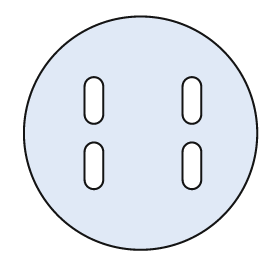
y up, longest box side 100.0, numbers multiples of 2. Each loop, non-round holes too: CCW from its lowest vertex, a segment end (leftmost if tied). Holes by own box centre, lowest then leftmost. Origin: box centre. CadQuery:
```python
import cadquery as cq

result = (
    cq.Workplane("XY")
    .moveTo(0.0, 0.0)
    .circle(50.0)
    .moveTo(-24.0, -20.0)
    .threePointArc((-20.0, -24.0), (-16.0, -20.0))
    .lineTo(-16.0, -8.0)
    .threePointArc((-20.0, -4.0), (-24.0, -8.0))
    .close()
    .moveTo(18.0, -20.0)
    .threePointArc((22.0, -24.0), (26.0, -20.0))
    .lineTo(26.0, -8.0)
    .threePointArc((22.0, -4.0), (18.0, -8.0))
    .close()
    .moveTo(-24.0, 8.0)
    .threePointArc((-20.0, 4.0), (-16.0, 8.0))
    .lineTo(-16.0, 20.0)
    .threePointArc((-20.0, 24.0), (-24.0, 20.0))
    .close()
    .moveTo(18.0, 8.0)
    .threePointArc((22.0, 4.0), (26.0, 8.0))
    .lineTo(26.0, 20.0)
    .threePointArc((22.0, 24.0), (18.0, 20.0))
    .close()
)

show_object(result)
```